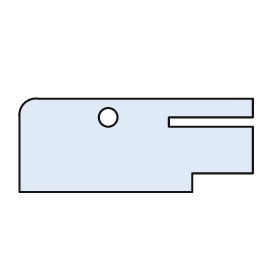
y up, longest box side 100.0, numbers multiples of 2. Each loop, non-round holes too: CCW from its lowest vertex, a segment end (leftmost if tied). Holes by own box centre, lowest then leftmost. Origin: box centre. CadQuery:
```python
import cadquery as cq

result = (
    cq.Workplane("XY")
    .moveTo(-50.0, -20.0)
    .lineTo(24.0, -20.0)
    .lineTo(24.0, -12.0)
    .lineTo(50.0, -12.0)
    .lineTo(50.0, 8.0)
    .lineTo(14.0, 8.0)
    .lineTo(14.0, 12.0)
    .lineTo(50.0, 12.0)
    .lineTo(50.0, 20.0)
    .lineTo(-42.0, 20.0)
    .threePointArc((-48.0, 18.0), (-50.0, 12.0))
    .close()
    .moveTo(-12.0, 12.0)
    .circle(4.0)
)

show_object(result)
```